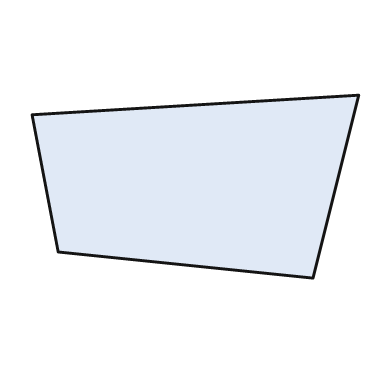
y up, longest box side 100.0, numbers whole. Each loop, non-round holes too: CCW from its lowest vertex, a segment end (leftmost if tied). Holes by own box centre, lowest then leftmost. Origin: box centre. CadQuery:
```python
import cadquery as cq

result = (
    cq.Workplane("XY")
    .moveTo(36.0, -28.0)
    .lineTo(50.0, 28.0)
    .lineTo(-50.0, 22.0)
    .lineTo(-42.0, -20.0)
    .close()
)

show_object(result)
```